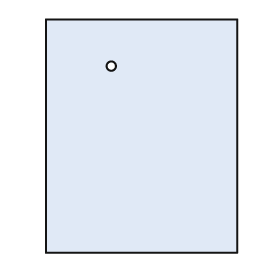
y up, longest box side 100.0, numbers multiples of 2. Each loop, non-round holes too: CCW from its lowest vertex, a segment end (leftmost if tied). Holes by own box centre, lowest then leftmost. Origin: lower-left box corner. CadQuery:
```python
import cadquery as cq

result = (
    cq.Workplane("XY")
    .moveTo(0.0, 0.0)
    .lineTo(82.0, 0.0)
    .lineTo(82.0, 100.0)
    .lineTo(0.0, 100.0)
    .close()
    .moveTo(28.0, 80.0)
    .circle(2.0)
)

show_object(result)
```